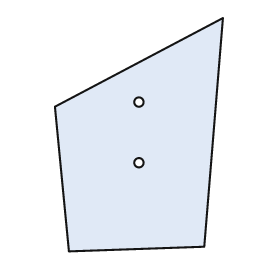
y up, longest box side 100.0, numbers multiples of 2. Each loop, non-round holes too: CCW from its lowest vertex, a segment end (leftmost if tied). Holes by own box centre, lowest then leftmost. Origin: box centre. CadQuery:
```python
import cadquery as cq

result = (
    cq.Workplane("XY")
    .moveTo(-30.0, -50.0)
    .lineTo(28.0, -48.0)
    .lineTo(36.0, 50.0)
    .lineTo(-36.0, 12.0)
    .close()
    .moveTo(0.0, -12.0)
    .circle(2.0)
    .moveTo(0.0, 14.0)
    .circle(2.0)
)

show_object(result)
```